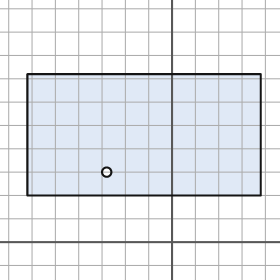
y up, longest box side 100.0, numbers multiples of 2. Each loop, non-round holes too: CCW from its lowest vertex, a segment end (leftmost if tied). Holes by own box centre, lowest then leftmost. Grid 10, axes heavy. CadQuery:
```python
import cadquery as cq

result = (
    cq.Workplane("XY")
    .moveTo(-62.0, 20.0)
    .lineTo(38.0, 20.0)
    .lineTo(38.0, 72.0)
    .lineTo(-62.0, 72.0)
    .close()
    .moveTo(-28.0, 30.0)
    .circle(2.0)
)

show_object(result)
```